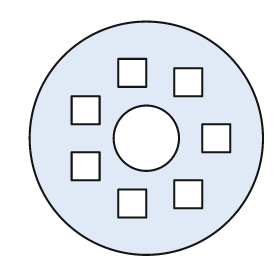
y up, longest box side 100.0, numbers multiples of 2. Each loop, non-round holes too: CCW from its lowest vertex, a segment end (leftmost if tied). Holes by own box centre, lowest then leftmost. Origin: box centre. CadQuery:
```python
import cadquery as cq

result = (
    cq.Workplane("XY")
    .moveTo(0.0, 0.0)
    .circle(50.0)
    .moveTo(-12.0, -34.0)
    .lineTo(0.0, -34.0)
    .lineTo(0.0, -22.0)
    .lineTo(-12.0, -22.0)
    .close()
    .moveTo(12.0, -30.0)
    .lineTo(24.0, -30.0)
    .lineTo(24.0, -18.0)
    .lineTo(12.0, -18.0)
    .close()
    .moveTo(-32.0, -18.0)
    .lineTo(-20.0, -18.0)
    .lineTo(-20.0, -6.0)
    .lineTo(-32.0, -6.0)
    .close()
    .moveTo(0.0, 0.0)
    .circle(14.0)
    .moveTo(24.0, -6.0)
    .lineTo(36.0, -6.0)
    .lineTo(36.0, 6.0)
    .lineTo(24.0, 6.0)
    .close()
    .moveTo(-32.0, 6.0)
    .lineTo(-20.0, 6.0)
    .lineTo(-20.0, 18.0)
    .lineTo(-32.0, 18.0)
    .close()
    .moveTo(12.0, 18.0)
    .lineTo(24.0, 18.0)
    .lineTo(24.0, 30.0)
    .lineTo(12.0, 30.0)
    .close()
    .moveTo(-12.0, 22.0)
    .lineTo(0.0, 22.0)
    .lineTo(0.0, 34.0)
    .lineTo(-12.0, 34.0)
    .close()
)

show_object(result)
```